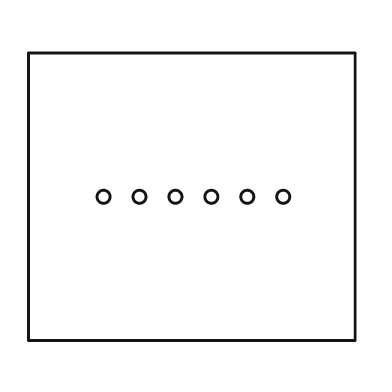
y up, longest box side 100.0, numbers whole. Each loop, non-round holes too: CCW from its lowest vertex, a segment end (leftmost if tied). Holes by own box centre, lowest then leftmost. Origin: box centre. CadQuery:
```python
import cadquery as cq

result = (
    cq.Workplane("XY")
    .moveTo(-50.0, -44.0)
    .lineTo(50.0, -44.0)
    .lineTo(50.0, 44.0)
    .lineTo(-50.0, 44.0)
    .close()
    .moveTo(-27.0, 0.0)
    .circle(2.0)
    .moveTo(-16.0, 0.0)
    .circle(2.0)
    .moveTo(-5.0, 0.0)
    .circle(2.0)
    .moveTo(6.0, 0.0)
    .circle(2.0)
    .moveTo(17.0, 0.0)
    .circle(2.0)
    .moveTo(28.0, 0.0)
    .circle(2.0)
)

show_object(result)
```